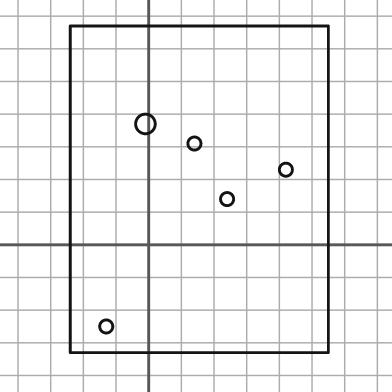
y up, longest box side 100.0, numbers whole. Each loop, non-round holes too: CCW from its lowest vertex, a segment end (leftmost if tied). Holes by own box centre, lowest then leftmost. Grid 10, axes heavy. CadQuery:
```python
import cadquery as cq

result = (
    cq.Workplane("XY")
    .moveTo(-24.0, -33.0)
    .lineTo(55.0, -33.0)
    .lineTo(55.0, 67.0)
    .lineTo(-24.0, 67.0)
    .close()
    .moveTo(-13.0, -25.0)
    .circle(2.0)
    .moveTo(24.0, 14.0)
    .circle(2.0)
    .moveTo(42.0, 23.0)
    .circle(2.0)
    .moveTo(14.0, 31.0)
    .circle(2.0)
    .moveTo(-1.0, 37.0)
    .circle(3.0)
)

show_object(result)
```